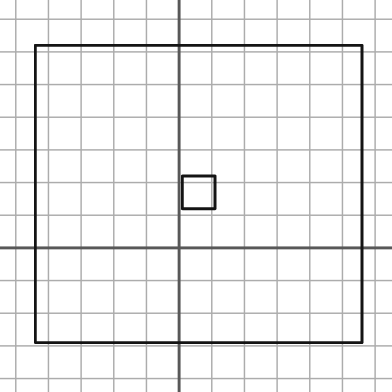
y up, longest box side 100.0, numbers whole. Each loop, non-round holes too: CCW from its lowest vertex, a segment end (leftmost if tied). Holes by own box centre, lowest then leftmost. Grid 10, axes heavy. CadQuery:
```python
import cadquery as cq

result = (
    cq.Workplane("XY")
    .moveTo(-44.0, -29.0)
    .lineTo(56.0, -29.0)
    .lineTo(56.0, 62.0)
    .lineTo(-44.0, 62.0)
    .close()
    .moveTo(1.0, 12.0)
    .lineTo(11.0, 12.0)
    .lineTo(11.0, 22.0)
    .lineTo(1.0, 22.0)
    .close()
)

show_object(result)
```